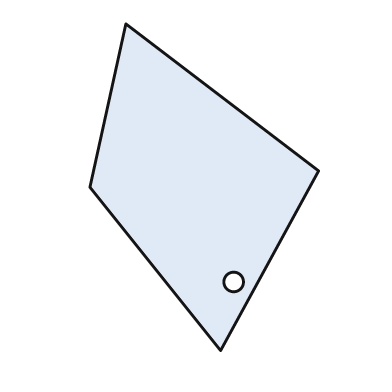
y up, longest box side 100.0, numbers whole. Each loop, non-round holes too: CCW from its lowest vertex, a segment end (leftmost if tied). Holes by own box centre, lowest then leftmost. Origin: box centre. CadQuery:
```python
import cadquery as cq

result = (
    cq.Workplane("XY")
    .moveTo(5.0, -50.0)
    .lineTo(35.0, 5.0)
    .lineTo(-24.0, 50.0)
    .lineTo(-35.0, 0.0)
    .close()
    .moveTo(9.0, -29.0)
    .circle(3.0)
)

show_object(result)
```